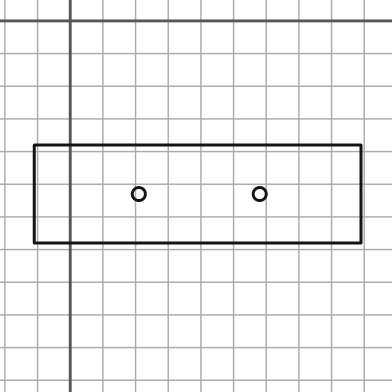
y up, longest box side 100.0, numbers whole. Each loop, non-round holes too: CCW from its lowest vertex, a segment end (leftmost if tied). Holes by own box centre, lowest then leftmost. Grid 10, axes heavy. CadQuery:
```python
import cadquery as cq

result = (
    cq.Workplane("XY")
    .moveTo(-11.0, -68.0)
    .lineTo(89.0, -68.0)
    .lineTo(89.0, -38.0)
    .lineTo(-11.0, -38.0)
    .close()
    .moveTo(21.0, -53.0)
    .circle(2.0)
    .moveTo(58.0, -53.0)
    .circle(2.0)
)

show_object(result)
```